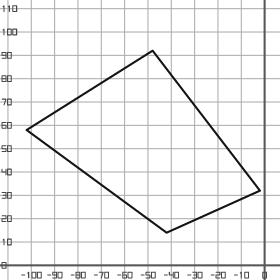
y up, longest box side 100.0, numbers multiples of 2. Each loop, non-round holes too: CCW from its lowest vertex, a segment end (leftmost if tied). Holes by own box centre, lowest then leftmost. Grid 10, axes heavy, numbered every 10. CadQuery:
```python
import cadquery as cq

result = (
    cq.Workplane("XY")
    .moveTo(-42.0, 14.0)
    .lineTo(-2.0, 32.0)
    .lineTo(-48.0, 92.0)
    .lineTo(-102.0, 58.0)
    .close()
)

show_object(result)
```